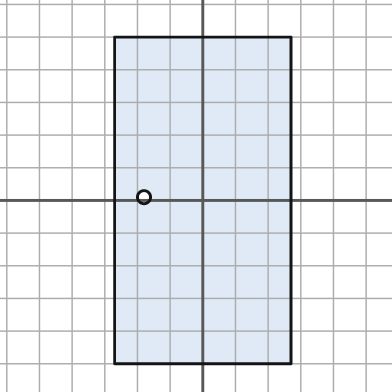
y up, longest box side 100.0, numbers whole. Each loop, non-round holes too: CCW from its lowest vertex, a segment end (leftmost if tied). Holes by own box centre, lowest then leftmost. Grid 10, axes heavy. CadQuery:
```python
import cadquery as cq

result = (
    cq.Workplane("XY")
    .moveTo(-27.0, -50.0)
    .lineTo(27.0, -50.0)
    .lineTo(27.0, 50.0)
    .lineTo(-27.0, 50.0)
    .close()
    .moveTo(-18.0, 1.0)
    .circle(2.0)
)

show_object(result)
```